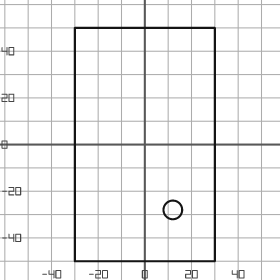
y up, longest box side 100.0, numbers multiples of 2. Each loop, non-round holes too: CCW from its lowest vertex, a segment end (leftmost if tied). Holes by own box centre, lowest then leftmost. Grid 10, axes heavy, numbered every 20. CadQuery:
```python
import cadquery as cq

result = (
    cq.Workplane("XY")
    .moveTo(-30.0, -50.0)
    .lineTo(30.0, -50.0)
    .lineTo(30.0, 50.0)
    .lineTo(-30.0, 50.0)
    .close()
    .moveTo(12.0, -28.0)
    .circle(4.0)
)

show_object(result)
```